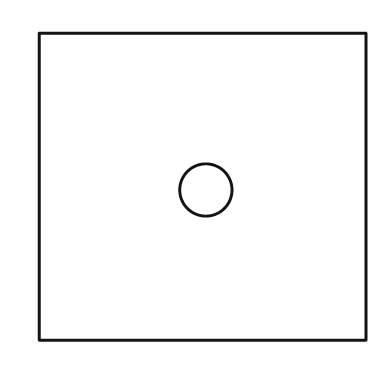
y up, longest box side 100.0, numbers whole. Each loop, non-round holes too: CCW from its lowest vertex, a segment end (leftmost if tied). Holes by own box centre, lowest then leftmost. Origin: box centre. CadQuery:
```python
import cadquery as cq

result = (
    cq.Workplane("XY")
    .moveTo(-50.0, -47.0)
    .lineTo(50.0, -47.0)
    .lineTo(50.0, 47.0)
    .lineTo(-50.0, 47.0)
    .close()
    .moveTo(1.0, -1.0)
    .circle(8.0)
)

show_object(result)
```